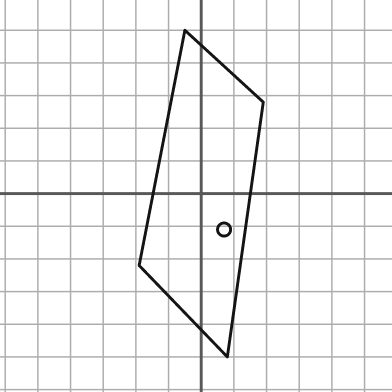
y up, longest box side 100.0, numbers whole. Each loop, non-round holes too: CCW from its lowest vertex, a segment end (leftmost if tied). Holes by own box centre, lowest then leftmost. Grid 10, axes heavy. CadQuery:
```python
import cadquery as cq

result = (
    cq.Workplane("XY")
    .moveTo(8.0, -50.0)
    .lineTo(19.0, 28.0)
    .lineTo(-5.0, 50.0)
    .lineTo(-19.0, -22.0)
    .close()
    .moveTo(7.0, -11.0)
    .circle(2.0)
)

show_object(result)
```